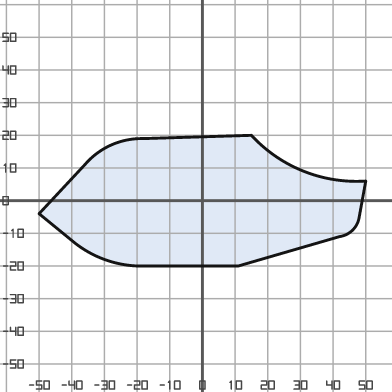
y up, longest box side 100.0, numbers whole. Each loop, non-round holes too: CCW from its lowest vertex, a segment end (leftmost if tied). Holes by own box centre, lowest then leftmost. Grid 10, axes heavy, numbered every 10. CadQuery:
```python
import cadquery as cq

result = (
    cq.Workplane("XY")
    .moveTo(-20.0, -20.0)
    .lineTo(11.0, -20.0)
    .lineTo(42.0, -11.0)
    .threePointArc((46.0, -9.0), (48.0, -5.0))
    .lineTo(50.0, 6.0)
    .threePointArc((31.0, 9.0), (15.0, 20.0))
    .lineTo(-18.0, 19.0)
    .threePointArc((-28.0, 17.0), (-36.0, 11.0))
    .lineTo(-50.0, -4.0)
    .lineTo(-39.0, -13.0)
    .threePointArc((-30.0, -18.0), (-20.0, -20.0))
    .close()
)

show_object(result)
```